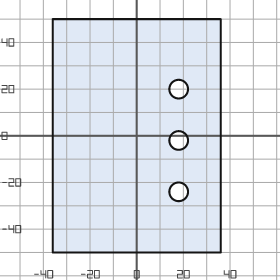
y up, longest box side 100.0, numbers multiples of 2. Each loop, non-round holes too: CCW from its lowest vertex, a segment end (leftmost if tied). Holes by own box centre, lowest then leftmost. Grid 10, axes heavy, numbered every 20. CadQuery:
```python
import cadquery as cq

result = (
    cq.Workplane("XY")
    .moveTo(-36.0, -50.0)
    .lineTo(36.0, -50.0)
    .lineTo(36.0, 50.0)
    .lineTo(-36.0, 50.0)
    .close()
    .moveTo(18.0, -24.0)
    .circle(4.0)
    .moveTo(18.0, -2.0)
    .circle(4.0)
    .moveTo(18.0, 20.0)
    .circle(4.0)
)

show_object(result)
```